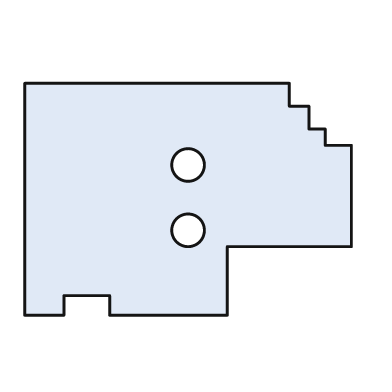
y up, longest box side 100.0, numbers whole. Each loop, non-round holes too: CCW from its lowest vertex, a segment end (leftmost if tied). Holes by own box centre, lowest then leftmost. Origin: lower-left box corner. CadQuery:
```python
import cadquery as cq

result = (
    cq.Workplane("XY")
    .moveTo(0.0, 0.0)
    .lineTo(12.0, 0.0)
    .lineTo(12.0, 6.0)
    .lineTo(26.0, 6.0)
    .lineTo(26.0, 0.0)
    .lineTo(62.0, 0.0)
    .lineTo(62.0, 21.0)
    .lineTo(100.0, 21.0)
    .lineTo(100.0, 52.0)
    .lineTo(92.0, 52.0)
    .lineTo(92.0, 57.0)
    .lineTo(87.0, 57.0)
    .lineTo(87.0, 64.0)
    .lineTo(81.0, 64.0)
    .lineTo(81.0, 71.0)
    .lineTo(0.0, 71.0)
    .close()
    .moveTo(50.0, 26.0)
    .circle(5.0)
    .moveTo(50.0, 46.0)
    .circle(5.0)
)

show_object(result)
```